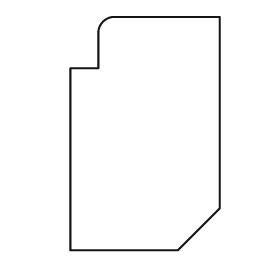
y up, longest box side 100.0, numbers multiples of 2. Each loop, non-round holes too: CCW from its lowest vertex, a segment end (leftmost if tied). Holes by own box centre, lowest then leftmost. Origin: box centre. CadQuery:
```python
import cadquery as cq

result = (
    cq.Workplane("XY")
    .moveTo(-32.0, -50.0)
    .lineTo(14.0, -50.0)
    .lineTo(32.0, -32.0)
    .lineTo(32.0, 50.0)
    .lineTo(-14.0, 50.0)
    .threePointArc((-18.0, 48.0), (-20.0, 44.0))
    .lineTo(-20.0, 28.0)
    .lineTo(-32.0, 28.0)
    .close()
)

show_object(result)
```